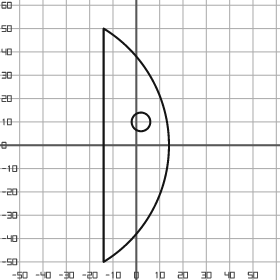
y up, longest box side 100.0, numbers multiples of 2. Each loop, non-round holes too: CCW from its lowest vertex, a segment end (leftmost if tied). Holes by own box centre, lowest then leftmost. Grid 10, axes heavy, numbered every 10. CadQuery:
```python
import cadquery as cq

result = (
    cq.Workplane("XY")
    .moveTo(-14.0, -50.0)
    .threePointArc((14.0, 0.0), (-14.0, 50.0))
    .close()
    .moveTo(2.0, 10.0)
    .circle(4.0)
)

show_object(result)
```